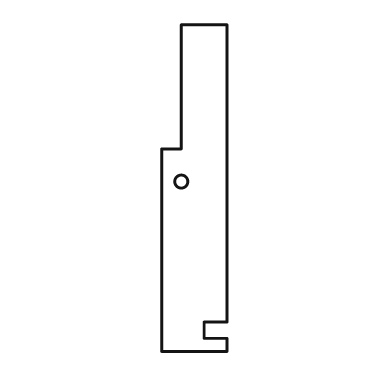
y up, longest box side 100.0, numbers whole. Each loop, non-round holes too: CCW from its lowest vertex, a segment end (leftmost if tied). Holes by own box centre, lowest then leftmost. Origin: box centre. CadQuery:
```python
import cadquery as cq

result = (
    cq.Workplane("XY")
    .moveTo(-10.0, -50.0)
    .lineTo(10.0, -50.0)
    .lineTo(10.0, -46.0)
    .lineTo(3.0, -46.0)
    .lineTo(3.0, -41.0)
    .lineTo(10.0, -41.0)
    .lineTo(10.0, 50.0)
    .lineTo(-4.0, 50.0)
    .lineTo(-4.0, 12.0)
    .lineTo(-10.0, 12.0)
    .close()
    .moveTo(-4.0, 2.0)
    .circle(2.0)
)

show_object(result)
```